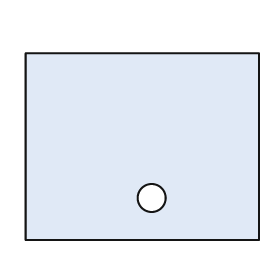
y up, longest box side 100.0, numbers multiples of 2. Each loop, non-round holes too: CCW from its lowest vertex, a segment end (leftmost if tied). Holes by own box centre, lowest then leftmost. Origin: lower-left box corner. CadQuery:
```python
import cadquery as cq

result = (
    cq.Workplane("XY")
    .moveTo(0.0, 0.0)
    .lineTo(100.0, 0.0)
    .lineTo(100.0, 80.0)
    .lineTo(0.0, 80.0)
    .close()
    .moveTo(54.0, 18.0)
    .circle(6.0)
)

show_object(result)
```